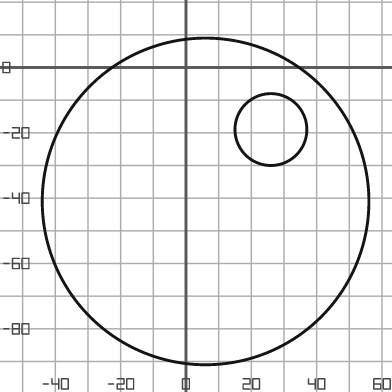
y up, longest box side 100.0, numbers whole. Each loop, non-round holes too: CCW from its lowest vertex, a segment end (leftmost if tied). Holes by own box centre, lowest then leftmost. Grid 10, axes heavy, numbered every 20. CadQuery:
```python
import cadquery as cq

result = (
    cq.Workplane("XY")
    .moveTo(6.0, -41.0)
    .circle(50.0)
    .moveTo(26.0, -19.0)
    .circle(11.0)
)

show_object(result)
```